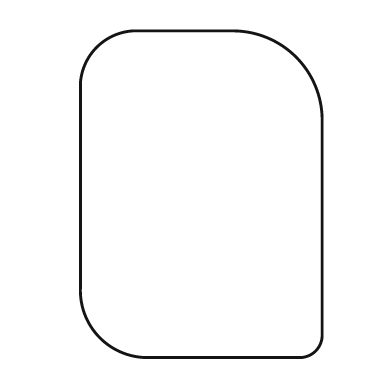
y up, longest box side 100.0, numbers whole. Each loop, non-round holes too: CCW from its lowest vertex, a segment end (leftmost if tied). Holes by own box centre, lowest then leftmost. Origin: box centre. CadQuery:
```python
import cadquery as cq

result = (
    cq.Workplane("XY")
    .moveTo(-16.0, -50.0)
    .lineTo(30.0, -50.0)
    .threePointArc((35.0, -48.0), (37.0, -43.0))
    .lineTo(37.0, 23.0)
    .threePointArc((29.0, 42.0), (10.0, 50.0))
    .lineTo(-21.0, 50.0)
    .threePointArc((-32.0, 45.0), (-37.0, 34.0))
    .lineTo(-37.0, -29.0)
    .threePointArc((-31.0, -44.0), (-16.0, -50.0))
    .close()
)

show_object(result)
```